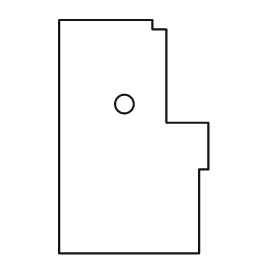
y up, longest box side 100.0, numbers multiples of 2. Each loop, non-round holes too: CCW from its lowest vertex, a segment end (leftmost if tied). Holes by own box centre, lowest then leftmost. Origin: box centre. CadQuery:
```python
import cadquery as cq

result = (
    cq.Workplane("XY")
    .moveTo(-32.0, -50.0)
    .lineTo(28.0, -50.0)
    .lineTo(28.0, -14.0)
    .lineTo(32.0, -14.0)
    .lineTo(32.0, 6.0)
    .lineTo(14.0, 6.0)
    .lineTo(14.0, 46.0)
    .lineTo(8.0, 46.0)
    .lineTo(8.0, 50.0)
    .lineTo(-32.0, 50.0)
    .close()
    .moveTo(-4.0, 14.0)
    .circle(4.0)
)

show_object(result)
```